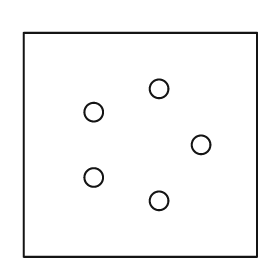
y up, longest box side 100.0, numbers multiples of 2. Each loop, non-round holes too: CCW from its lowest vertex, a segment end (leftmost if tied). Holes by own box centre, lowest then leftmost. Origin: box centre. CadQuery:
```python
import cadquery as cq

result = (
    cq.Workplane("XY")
    .moveTo(-50.0, -48.0)
    .lineTo(50.0, -48.0)
    .lineTo(50.0, 48.0)
    .lineTo(-50.0, 48.0)
    .close()
    .moveTo(8.0, -24.0)
    .circle(4.0)
    .moveTo(-20.0, -14.0)
    .circle(4.0)
    .moveTo(26.0, 0.0)
    .circle(4.0)
    .moveTo(-20.0, 14.0)
    .circle(4.0)
    .moveTo(8.0, 24.0)
    .circle(4.0)
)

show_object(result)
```